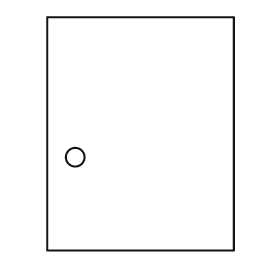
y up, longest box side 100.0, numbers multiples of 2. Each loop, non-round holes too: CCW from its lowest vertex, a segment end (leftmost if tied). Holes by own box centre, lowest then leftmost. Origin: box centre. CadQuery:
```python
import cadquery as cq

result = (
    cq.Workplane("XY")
    .moveTo(-40.0, -50.0)
    .lineTo(40.0, -50.0)
    .lineTo(40.0, 50.0)
    .lineTo(-40.0, 50.0)
    .close()
    .moveTo(-28.0, -10.0)
    .circle(4.0)
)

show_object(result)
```